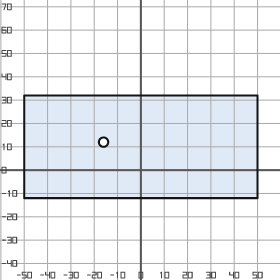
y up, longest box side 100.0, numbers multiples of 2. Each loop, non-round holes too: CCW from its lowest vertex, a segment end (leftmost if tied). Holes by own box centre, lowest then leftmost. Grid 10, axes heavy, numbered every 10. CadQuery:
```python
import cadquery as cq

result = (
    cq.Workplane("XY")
    .moveTo(-50.0, -12.0)
    .lineTo(50.0, -12.0)
    .lineTo(50.0, 32.0)
    .lineTo(-50.0, 32.0)
    .close()
    .moveTo(-16.0, 12.0)
    .circle(2.0)
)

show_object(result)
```